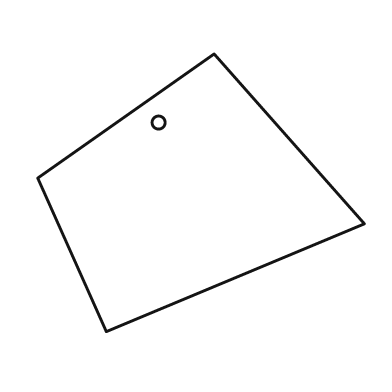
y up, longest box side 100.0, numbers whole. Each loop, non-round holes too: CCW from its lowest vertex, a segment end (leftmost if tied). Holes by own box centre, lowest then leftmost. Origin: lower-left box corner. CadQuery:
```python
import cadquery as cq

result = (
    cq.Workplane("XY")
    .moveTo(21.0, 0.0)
    .lineTo(100.0, 33.0)
    .lineTo(54.0, 85.0)
    .lineTo(0.0, 47.0)
    .close()
    .moveTo(37.0, 64.0)
    .circle(2.0)
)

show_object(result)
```